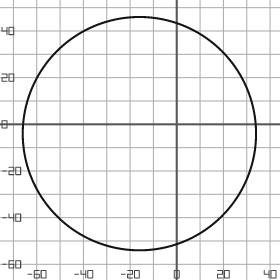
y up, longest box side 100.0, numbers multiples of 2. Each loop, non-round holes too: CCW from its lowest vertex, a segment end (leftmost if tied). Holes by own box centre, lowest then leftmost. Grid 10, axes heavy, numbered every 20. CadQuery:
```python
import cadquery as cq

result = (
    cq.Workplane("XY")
    .moveTo(-16.0, -4.0)
    .circle(50.0)
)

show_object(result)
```